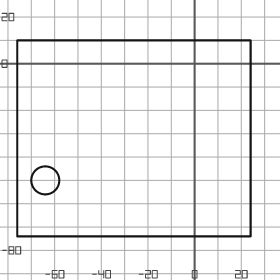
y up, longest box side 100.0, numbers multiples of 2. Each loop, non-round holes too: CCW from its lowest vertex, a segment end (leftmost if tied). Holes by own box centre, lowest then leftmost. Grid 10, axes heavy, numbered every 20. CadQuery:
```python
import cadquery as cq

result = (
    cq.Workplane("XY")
    .moveTo(-76.0, -74.0)
    .lineTo(24.0, -74.0)
    .lineTo(24.0, 10.0)
    .lineTo(-76.0, 10.0)
    .close()
    .moveTo(-64.0, -50.0)
    .circle(6.0)
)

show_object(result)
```